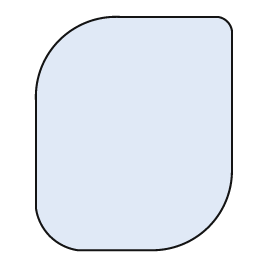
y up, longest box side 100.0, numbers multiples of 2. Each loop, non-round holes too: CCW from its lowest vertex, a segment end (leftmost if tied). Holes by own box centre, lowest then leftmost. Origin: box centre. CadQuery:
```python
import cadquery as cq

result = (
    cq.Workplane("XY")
    .moveTo(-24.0, -50.0)
    .lineTo(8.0, -50.0)
    .threePointArc((32.0, -40.0), (42.0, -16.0))
    .lineTo(42.0, 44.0)
    .threePointArc((40.0, 48.0), (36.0, 50.0))
    .lineTo(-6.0, 50.0)
    .threePointArc((-32.0, 40.0), (-42.0, 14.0))
    .lineTo(-42.0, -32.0)
    .threePointArc((-36.0, -44.0), (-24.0, -50.0))
    .close()
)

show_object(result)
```